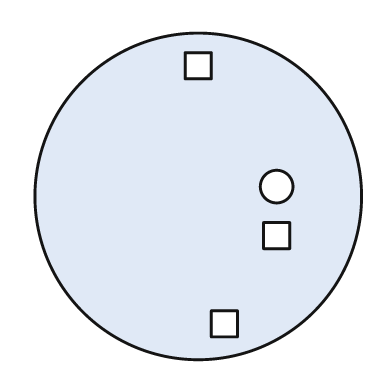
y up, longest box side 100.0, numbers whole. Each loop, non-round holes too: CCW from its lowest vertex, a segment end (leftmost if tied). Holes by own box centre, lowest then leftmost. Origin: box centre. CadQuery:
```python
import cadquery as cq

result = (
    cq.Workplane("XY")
    .moveTo(0.0, 0.0)
    .circle(50.0)
    .moveTo(4.0, -43.0)
    .lineTo(12.0, -43.0)
    .lineTo(12.0, -35.0)
    .lineTo(4.0, -35.0)
    .close()
    .moveTo(20.0, -16.0)
    .lineTo(28.0, -16.0)
    .lineTo(28.0, -8.0)
    .lineTo(20.0, -8.0)
    .close()
    .moveTo(24.0, 3.0)
    .circle(5.0)
    .moveTo(-4.0, 36.0)
    .lineTo(4.0, 36.0)
    .lineTo(4.0, 44.0)
    .lineTo(-4.0, 44.0)
    .close()
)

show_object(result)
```